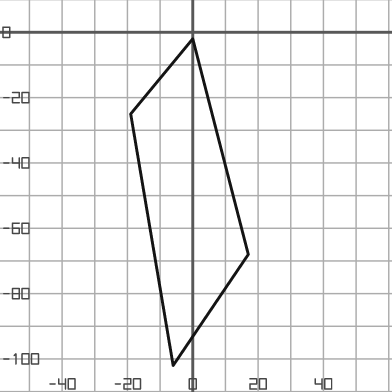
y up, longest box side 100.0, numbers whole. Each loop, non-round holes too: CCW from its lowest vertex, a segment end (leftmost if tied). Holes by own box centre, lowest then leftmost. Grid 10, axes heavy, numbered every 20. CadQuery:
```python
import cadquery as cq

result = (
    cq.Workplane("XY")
    .moveTo(-6.0, -102.0)
    .lineTo(17.0, -68.0)
    .lineTo(0.0, -2.0)
    .lineTo(-19.0, -25.0)
    .close()
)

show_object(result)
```